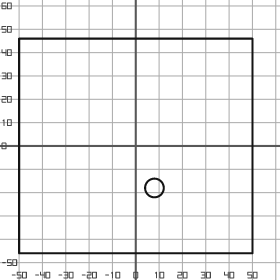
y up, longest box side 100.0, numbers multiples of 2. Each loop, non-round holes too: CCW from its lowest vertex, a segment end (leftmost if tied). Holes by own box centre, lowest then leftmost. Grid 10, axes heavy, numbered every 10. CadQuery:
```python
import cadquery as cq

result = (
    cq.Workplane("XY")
    .moveTo(-50.0, -46.0)
    .lineTo(50.0, -46.0)
    .lineTo(50.0, 46.0)
    .lineTo(-50.0, 46.0)
    .close()
    .moveTo(8.0, -18.0)
    .circle(4.0)
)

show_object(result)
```